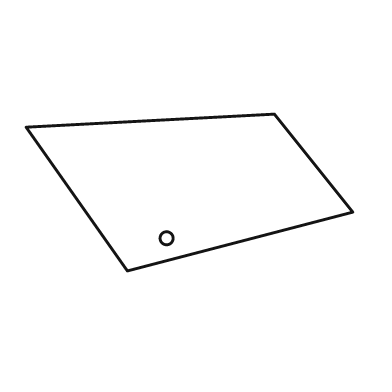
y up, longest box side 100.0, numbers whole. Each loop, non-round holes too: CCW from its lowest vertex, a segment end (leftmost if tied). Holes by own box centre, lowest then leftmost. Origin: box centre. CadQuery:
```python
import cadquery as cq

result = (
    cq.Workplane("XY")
    .moveTo(-19.0, -24.0)
    .lineTo(50.0, -6.0)
    .lineTo(26.0, 24.0)
    .lineTo(-50.0, 20.0)
    .close()
    .moveTo(-7.0, -14.0)
    .circle(2.0)
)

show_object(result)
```